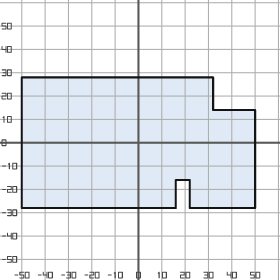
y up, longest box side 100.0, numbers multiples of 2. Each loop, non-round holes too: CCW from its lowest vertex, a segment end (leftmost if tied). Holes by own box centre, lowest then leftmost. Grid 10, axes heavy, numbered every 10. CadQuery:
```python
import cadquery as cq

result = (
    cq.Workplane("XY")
    .moveTo(-50.0, -28.0)
    .lineTo(16.0, -28.0)
    .lineTo(16.0, -16.0)
    .lineTo(22.0, -16.0)
    .lineTo(22.0, -28.0)
    .lineTo(50.0, -28.0)
    .lineTo(50.0, 14.0)
    .lineTo(32.0, 14.0)
    .lineTo(32.0, 28.0)
    .lineTo(-50.0, 28.0)
    .close()
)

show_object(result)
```